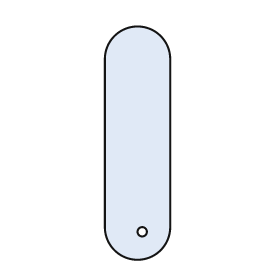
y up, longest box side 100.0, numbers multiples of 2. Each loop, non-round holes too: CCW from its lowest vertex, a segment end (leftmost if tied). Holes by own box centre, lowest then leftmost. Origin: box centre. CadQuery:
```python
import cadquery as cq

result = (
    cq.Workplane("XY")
    .moveTo(-14.0, -36.0)
    .threePointArc((0.0, -50.0), (14.0, -36.0))
    .lineTo(14.0, 36.0)
    .threePointArc((0.0, 50.0), (-14.0, 36.0))
    .close()
    .moveTo(2.0, -38.0)
    .circle(2.0)
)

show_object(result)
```